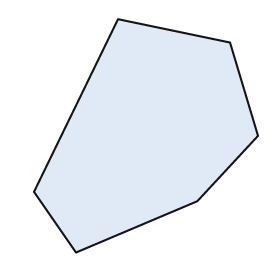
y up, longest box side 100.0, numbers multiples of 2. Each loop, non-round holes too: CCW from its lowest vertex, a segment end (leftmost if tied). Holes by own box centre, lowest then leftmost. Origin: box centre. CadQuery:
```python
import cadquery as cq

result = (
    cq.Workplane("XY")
    .moveTo(-30.0, -50.0)
    .lineTo(22.0, -28.0)
    .lineTo(48.0, 0.0)
    .lineTo(36.0, 40.0)
    .lineTo(-12.0, 50.0)
    .lineTo(-48.0, -24.0)
    .close()
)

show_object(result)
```